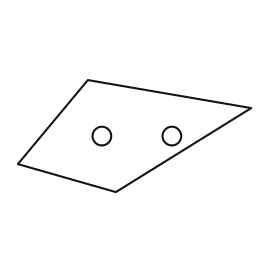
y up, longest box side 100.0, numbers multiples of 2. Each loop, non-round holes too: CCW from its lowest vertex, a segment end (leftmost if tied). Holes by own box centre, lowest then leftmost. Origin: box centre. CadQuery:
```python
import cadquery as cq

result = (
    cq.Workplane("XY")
    .moveTo(-8.0, -24.0)
    .lineTo(50.0, 12.0)
    .lineTo(-20.0, 24.0)
    .lineTo(-50.0, -12.0)
    .close()
    .moveTo(-14.0, 0.0)
    .circle(4.0)
    .moveTo(16.0, 0.0)
    .circle(4.0)
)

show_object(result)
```